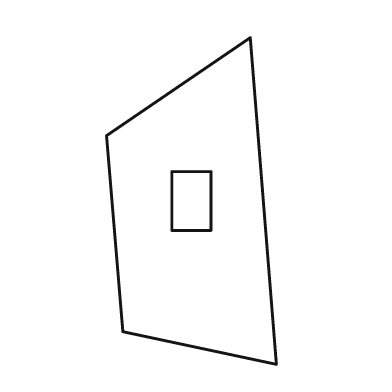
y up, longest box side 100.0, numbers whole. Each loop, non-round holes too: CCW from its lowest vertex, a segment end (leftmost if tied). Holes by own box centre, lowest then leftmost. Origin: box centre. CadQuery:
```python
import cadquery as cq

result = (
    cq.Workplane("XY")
    .moveTo(26.0, -50.0)
    .lineTo(18.0, 50.0)
    .lineTo(-26.0, 20.0)
    .lineTo(-21.0, -40.0)
    .close()
    .moveTo(-6.0, -9.0)
    .lineTo(6.0, -9.0)
    .lineTo(6.0, 9.0)
    .lineTo(-6.0, 9.0)
    .close()
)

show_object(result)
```